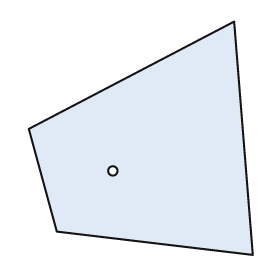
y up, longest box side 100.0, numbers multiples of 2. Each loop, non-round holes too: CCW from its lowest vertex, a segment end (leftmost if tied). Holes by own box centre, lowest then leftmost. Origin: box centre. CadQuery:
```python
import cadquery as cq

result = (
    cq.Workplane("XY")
    .moveTo(48.0, -50.0)
    .lineTo(40.0, 50.0)
    .lineTo(-48.0, 4.0)
    .lineTo(-36.0, -40.0)
    .close()
    .moveTo(-12.0, -14.0)
    .circle(2.0)
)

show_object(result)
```